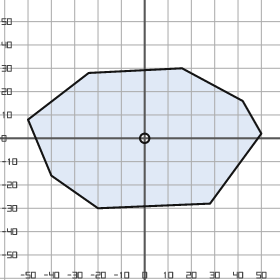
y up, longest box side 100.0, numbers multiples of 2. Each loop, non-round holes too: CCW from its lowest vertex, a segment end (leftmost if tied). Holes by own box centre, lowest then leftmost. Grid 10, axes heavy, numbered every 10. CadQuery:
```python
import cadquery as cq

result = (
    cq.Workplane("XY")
    .moveTo(-20.0, -30.0)
    .lineTo(28.0, -28.0)
    .lineTo(50.0, 2.0)
    .lineTo(42.0, 16.0)
    .lineTo(16.0, 30.0)
    .lineTo(-24.0, 28.0)
    .lineTo(-50.0, 8.0)
    .lineTo(-40.0, -16.0)
    .close()
    .moveTo(0.0, 0.0)
    .circle(2.0)
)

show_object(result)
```